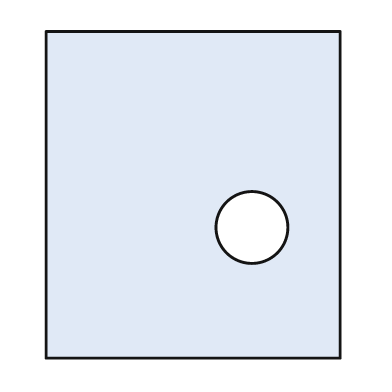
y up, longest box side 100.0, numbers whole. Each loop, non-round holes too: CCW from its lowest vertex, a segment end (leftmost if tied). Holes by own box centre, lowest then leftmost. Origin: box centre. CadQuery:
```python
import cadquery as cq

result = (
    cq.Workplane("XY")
    .moveTo(-45.0, -50.0)
    .lineTo(45.0, -50.0)
    .lineTo(45.0, 50.0)
    .lineTo(-45.0, 50.0)
    .close()
    .moveTo(18.0, -10.0)
    .circle(11.0)
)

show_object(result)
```